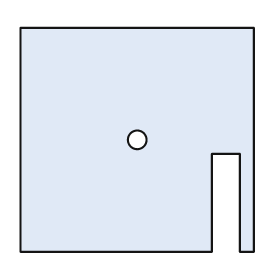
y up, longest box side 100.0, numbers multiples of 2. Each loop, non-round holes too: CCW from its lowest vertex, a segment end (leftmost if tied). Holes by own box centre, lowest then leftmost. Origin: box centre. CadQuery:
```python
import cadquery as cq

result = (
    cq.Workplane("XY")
    .moveTo(-50.0, -48.0)
    .lineTo(32.0, -48.0)
    .lineTo(32.0, -6.0)
    .lineTo(44.0, -6.0)
    .lineTo(44.0, -48.0)
    .lineTo(50.0, -48.0)
    .lineTo(50.0, 48.0)
    .lineTo(-50.0, 48.0)
    .close()
    .moveTo(0.0, 0.0)
    .circle(4.0)
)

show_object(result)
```